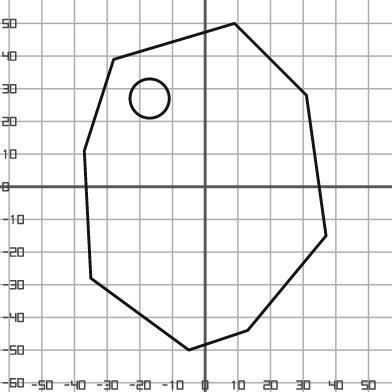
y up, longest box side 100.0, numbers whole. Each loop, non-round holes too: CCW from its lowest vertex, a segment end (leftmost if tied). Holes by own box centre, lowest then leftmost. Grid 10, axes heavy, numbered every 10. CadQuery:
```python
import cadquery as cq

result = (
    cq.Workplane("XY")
    .moveTo(-5.0, -50.0)
    .lineTo(13.0, -44.0)
    .lineTo(37.0, -15.0)
    .lineTo(31.0, 28.0)
    .lineTo(9.0, 50.0)
    .lineTo(-28.0, 39.0)
    .lineTo(-37.0, 11.0)
    .lineTo(-35.0, -28.0)
    .close()
    .moveTo(-17.0, 27.0)
    .circle(6.0)
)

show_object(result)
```